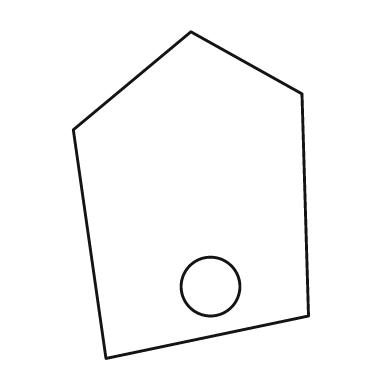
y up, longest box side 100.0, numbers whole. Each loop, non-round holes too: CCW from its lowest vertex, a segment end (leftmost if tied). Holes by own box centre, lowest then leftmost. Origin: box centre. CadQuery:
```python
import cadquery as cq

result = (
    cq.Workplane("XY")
    .moveTo(-26.0, -50.0)
    .lineTo(36.0, -37.0)
    .lineTo(34.0, 31.0)
    .lineTo(0.0, 50.0)
    .lineTo(-36.0, 20.0)
    .close()
    .moveTo(6.0, -28.0)
    .circle(9.0)
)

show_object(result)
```